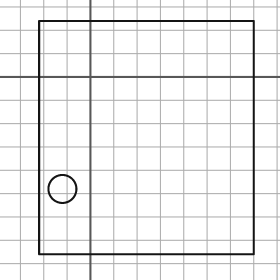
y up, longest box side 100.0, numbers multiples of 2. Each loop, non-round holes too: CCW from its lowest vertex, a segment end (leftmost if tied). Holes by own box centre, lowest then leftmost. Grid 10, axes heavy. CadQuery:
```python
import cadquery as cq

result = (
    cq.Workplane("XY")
    .moveTo(-22.0, -76.0)
    .lineTo(70.0, -76.0)
    .lineTo(70.0, 24.0)
    .lineTo(-22.0, 24.0)
    .close()
    .moveTo(-12.0, -48.0)
    .circle(6.0)
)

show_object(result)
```